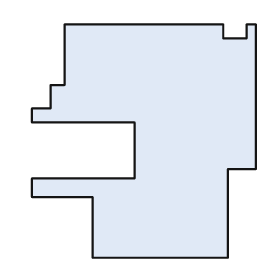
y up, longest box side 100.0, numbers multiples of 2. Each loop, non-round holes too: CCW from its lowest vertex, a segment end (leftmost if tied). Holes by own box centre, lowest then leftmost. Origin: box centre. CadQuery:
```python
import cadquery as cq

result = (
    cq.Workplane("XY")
    .moveTo(-22.0, -50.0)
    .lineTo(36.0, -50.0)
    .lineTo(36.0, -12.0)
    .lineTo(48.0, -12.0)
    .lineTo(48.0, 50.0)
    .lineTo(44.0, 50.0)
    .lineTo(44.0, 44.0)
    .lineTo(34.0, 44.0)
    .lineTo(34.0, 50.0)
    .lineTo(-34.0, 50.0)
    .lineTo(-34.0, 24.0)
    .lineTo(-40.0, 24.0)
    .lineTo(-40.0, 14.0)
    .lineTo(-48.0, 14.0)
    .lineTo(-48.0, 8.0)
    .lineTo(-4.0, 8.0)
    .lineTo(-4.0, -16.0)
    .lineTo(-48.0, -16.0)
    .lineTo(-48.0, -24.0)
    .lineTo(-22.0, -24.0)
    .close()
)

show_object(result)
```